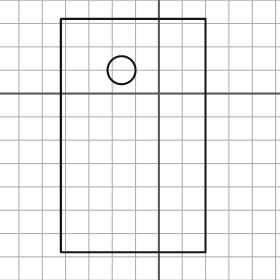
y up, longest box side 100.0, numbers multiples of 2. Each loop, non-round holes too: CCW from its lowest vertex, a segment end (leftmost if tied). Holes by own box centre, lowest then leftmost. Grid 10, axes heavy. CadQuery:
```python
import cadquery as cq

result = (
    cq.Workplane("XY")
    .moveTo(-42.0, -68.0)
    .lineTo(20.0, -68.0)
    .lineTo(20.0, 32.0)
    .lineTo(-42.0, 32.0)
    .close()
    .moveTo(-16.0, 10.0)
    .circle(6.0)
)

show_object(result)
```